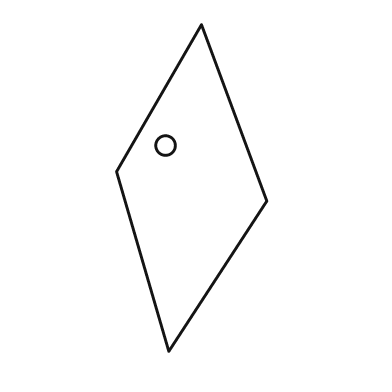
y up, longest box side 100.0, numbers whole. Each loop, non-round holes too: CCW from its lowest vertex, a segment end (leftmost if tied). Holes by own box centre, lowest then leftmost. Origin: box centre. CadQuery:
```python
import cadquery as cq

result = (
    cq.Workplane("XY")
    .moveTo(-7.0, -50.0)
    .lineTo(23.0, -4.0)
    .lineTo(3.0, 50.0)
    .lineTo(-23.0, 5.0)
    .close()
    .moveTo(-8.0, 13.0)
    .circle(3.0)
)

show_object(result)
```